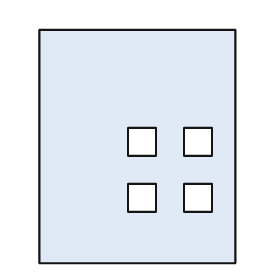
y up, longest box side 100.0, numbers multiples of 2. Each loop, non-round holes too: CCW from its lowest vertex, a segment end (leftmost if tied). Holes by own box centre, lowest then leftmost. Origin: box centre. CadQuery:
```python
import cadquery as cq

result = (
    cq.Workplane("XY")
    .moveTo(-42.0, -50.0)
    .lineTo(42.0, -50.0)
    .lineTo(42.0, 50.0)
    .lineTo(-42.0, 50.0)
    .close()
    .moveTo(-4.0, -28.0)
    .lineTo(8.0, -28.0)
    .lineTo(8.0, -16.0)
    .lineTo(-4.0, -16.0)
    .close()
    .moveTo(20.0, -28.0)
    .lineTo(32.0, -28.0)
    .lineTo(32.0, -16.0)
    .lineTo(20.0, -16.0)
    .close()
    .moveTo(-4.0, -4.0)
    .lineTo(8.0, -4.0)
    .lineTo(8.0, 8.0)
    .lineTo(-4.0, 8.0)
    .close()
    .moveTo(20.0, -4.0)
    .lineTo(32.0, -4.0)
    .lineTo(32.0, 8.0)
    .lineTo(20.0, 8.0)
    .close()
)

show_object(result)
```